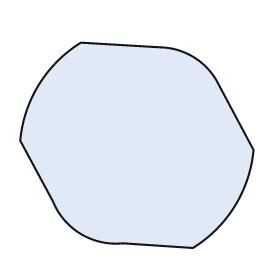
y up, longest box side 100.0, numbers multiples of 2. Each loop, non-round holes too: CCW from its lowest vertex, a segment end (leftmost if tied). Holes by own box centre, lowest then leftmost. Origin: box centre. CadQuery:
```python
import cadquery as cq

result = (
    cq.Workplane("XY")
    .moveTo(24.0, -44.0)
    .threePointArc((42.0, -26.0), (50.0, -2.0))
    .lineTo(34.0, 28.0)
    .threePointArc((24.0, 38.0), (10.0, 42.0))
    .lineTo(-24.0, 44.0)
    .threePointArc((-42.0, 26.0), (-50.0, 2.0))
    .lineTo(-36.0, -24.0)
    .threePointArc((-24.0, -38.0), (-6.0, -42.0))
    .close()
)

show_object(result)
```